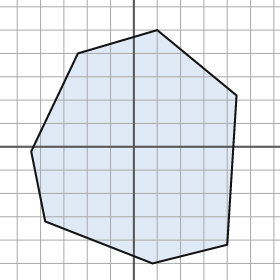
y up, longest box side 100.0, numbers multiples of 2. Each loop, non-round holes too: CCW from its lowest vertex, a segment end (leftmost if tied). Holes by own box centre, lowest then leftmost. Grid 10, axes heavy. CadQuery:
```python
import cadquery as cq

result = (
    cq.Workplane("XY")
    .moveTo(8.0, -50.0)
    .lineTo(40.0, -42.0)
    .lineTo(44.0, 22.0)
    .lineTo(10.0, 50.0)
    .lineTo(-24.0, 40.0)
    .lineTo(-44.0, -2.0)
    .lineTo(-38.0, -32.0)
    .close()
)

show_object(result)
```